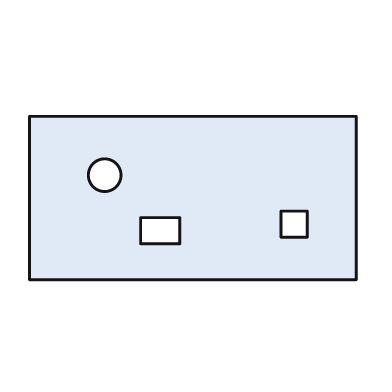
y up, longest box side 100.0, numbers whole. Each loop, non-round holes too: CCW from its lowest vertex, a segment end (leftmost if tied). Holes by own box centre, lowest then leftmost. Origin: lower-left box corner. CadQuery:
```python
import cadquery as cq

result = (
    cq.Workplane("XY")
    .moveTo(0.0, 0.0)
    .lineTo(100.0, 0.0)
    .lineTo(100.0, 50.0)
    .lineTo(0.0, 50.0)
    .close()
    .moveTo(34.0, 11.0)
    .lineTo(46.0, 11.0)
    .lineTo(46.0, 19.0)
    .lineTo(34.0, 19.0)
    .close()
    .moveTo(77.0, 13.0)
    .lineTo(85.0, 13.0)
    .lineTo(85.0, 21.0)
    .lineTo(77.0, 21.0)
    .close()
    .moveTo(23.0, 32.0)
    .circle(5.0)
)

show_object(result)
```